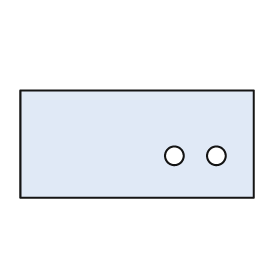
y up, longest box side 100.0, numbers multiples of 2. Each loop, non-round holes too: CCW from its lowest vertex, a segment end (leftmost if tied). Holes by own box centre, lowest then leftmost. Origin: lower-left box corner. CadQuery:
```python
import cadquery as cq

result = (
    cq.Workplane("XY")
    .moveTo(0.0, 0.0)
    .lineTo(100.0, 0.0)
    .lineTo(100.0, 46.0)
    .lineTo(0.0, 46.0)
    .close()
    .moveTo(66.0, 18.0)
    .circle(4.0)
    .moveTo(84.0, 18.0)
    .circle(4.0)
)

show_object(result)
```